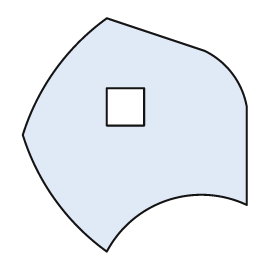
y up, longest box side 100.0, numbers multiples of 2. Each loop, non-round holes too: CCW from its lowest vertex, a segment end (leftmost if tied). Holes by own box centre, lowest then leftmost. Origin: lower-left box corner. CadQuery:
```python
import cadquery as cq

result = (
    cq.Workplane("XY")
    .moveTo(36.0, 0.0)
    .threePointArc((62.0, 22.0), (96.0, 20.0))
    .lineTo(96.0, 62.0)
    .threePointArc((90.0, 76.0), (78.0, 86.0))
    .lineTo(36.0, 100.0)
    .threePointArc((14.0, 78.0), (0.0, 50.0))
    .threePointArc((14.0, 22.0), (36.0, 0.0))
    .close()
    .moveTo(36.0, 54.0)
    .lineTo(52.0, 54.0)
    .lineTo(52.0, 70.0)
    .lineTo(36.0, 70.0)
    .close()
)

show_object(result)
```